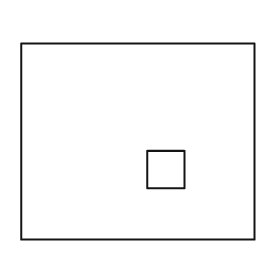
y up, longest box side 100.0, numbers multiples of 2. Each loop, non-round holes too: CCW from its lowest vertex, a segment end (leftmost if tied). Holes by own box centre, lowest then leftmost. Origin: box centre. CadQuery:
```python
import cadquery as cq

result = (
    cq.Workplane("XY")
    .moveTo(-50.0, -42.0)
    .lineTo(50.0, -42.0)
    .lineTo(50.0, 42.0)
    .lineTo(-50.0, 42.0)
    .close()
    .moveTo(4.0, -20.0)
    .lineTo(20.0, -20.0)
    .lineTo(20.0, -4.0)
    .lineTo(4.0, -4.0)
    .close()
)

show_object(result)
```